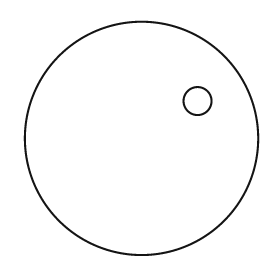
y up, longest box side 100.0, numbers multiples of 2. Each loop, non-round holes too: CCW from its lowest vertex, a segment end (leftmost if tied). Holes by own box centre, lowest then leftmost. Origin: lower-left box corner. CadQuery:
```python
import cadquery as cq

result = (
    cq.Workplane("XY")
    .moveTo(50.0, 50.0)
    .circle(50.0)
    .moveTo(74.0, 66.0)
    .circle(6.0)
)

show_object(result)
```